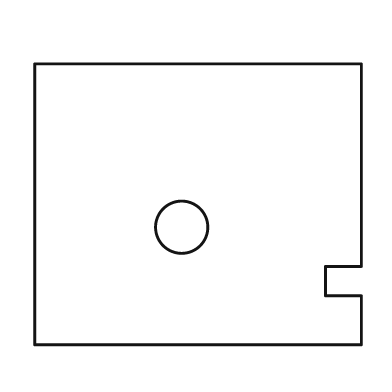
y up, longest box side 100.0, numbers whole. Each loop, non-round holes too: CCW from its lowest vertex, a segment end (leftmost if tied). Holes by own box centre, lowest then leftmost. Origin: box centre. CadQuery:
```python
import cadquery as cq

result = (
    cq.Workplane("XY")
    .moveTo(-50.0, -43.0)
    .lineTo(50.0, -43.0)
    .lineTo(50.0, -28.0)
    .lineTo(39.0, -28.0)
    .lineTo(39.0, -19.0)
    .lineTo(50.0, -19.0)
    .lineTo(50.0, 43.0)
    .lineTo(-50.0, 43.0)
    .close()
    .moveTo(-5.0, -7.0)
    .circle(8.0)
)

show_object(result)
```